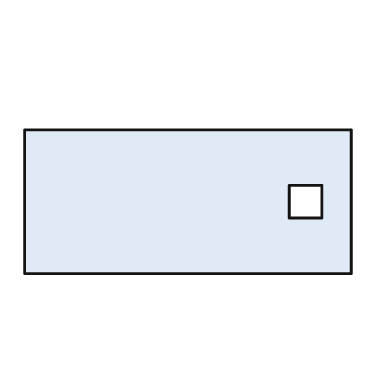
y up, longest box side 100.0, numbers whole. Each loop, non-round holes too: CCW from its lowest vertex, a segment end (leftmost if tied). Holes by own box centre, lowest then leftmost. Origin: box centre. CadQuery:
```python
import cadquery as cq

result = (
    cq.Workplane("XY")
    .moveTo(-50.0, -22.0)
    .lineTo(50.0, -22.0)
    .lineTo(50.0, 22.0)
    .lineTo(-50.0, 22.0)
    .close()
    .moveTo(31.0, -5.0)
    .lineTo(41.0, -5.0)
    .lineTo(41.0, 5.0)
    .lineTo(31.0, 5.0)
    .close()
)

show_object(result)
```